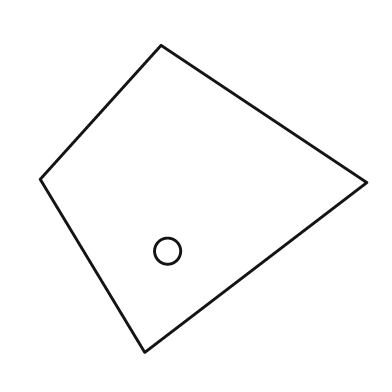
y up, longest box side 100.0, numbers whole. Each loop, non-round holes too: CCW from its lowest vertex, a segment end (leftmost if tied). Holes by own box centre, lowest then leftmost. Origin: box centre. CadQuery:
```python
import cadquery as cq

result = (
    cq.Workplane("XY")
    .moveTo(-18.0, -47.0)
    .lineTo(50.0, 5.0)
    .lineTo(-13.0, 47.0)
    .lineTo(-50.0, 6.0)
    .close()
    .moveTo(-11.0, -16.0)
    .circle(4.0)
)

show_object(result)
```